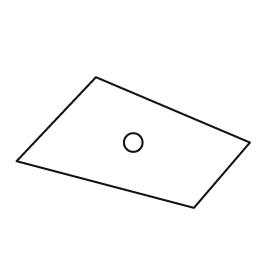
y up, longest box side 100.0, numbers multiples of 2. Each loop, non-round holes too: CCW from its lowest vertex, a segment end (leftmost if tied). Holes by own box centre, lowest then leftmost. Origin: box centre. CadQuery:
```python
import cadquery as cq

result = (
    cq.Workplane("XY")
    .moveTo(26.0, -28.0)
    .lineTo(50.0, 0.0)
    .lineTo(-16.0, 28.0)
    .lineTo(-50.0, -8.0)
    .close()
    .moveTo(0.0, 0.0)
    .circle(4.0)
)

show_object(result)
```